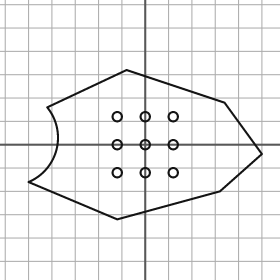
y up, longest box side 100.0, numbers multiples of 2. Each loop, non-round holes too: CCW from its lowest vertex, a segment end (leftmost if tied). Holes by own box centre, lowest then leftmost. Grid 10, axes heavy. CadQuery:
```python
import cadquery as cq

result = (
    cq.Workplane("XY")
    .moveTo(-12.0, -32.0)
    .lineTo(32.0, -20.0)
    .lineTo(50.0, -4.0)
    .lineTo(34.0, 18.0)
    .lineTo(-8.0, 32.0)
    .lineTo(-42.0, 16.0)
    .threePointArc((-38.0, -2.0), (-50.0, -16.0))
    .close()
    .moveTo(-12.0, -12.0)
    .circle(2.0)
    .moveTo(0.0, -12.0)
    .circle(2.0)
    .moveTo(12.0, -12.0)
    .circle(2.0)
    .moveTo(-12.0, 0.0)
    .circle(2.0)
    .moveTo(0.0, 0.0)
    .circle(2.0)
    .moveTo(12.0, 0.0)
    .circle(2.0)
    .moveTo(-12.0, 12.0)
    .circle(2.0)
    .moveTo(0.0, 12.0)
    .circle(2.0)
    .moveTo(12.0, 12.0)
    .circle(2.0)
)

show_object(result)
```